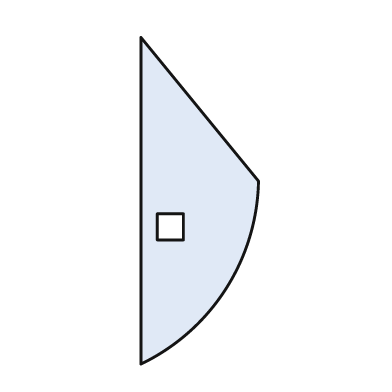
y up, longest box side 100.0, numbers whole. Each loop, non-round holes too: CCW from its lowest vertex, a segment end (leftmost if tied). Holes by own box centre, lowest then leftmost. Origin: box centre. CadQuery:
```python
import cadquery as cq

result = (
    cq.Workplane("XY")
    .moveTo(-18.0, -50.0)
    .threePointArc((8.0, -27.0), (18.0, 6.0))
    .lineTo(-18.0, 50.0)
    .close()
    .moveTo(-13.0, -12.0)
    .lineTo(-5.0, -12.0)
    .lineTo(-5.0, -4.0)
    .lineTo(-13.0, -4.0)
    .close()
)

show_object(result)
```